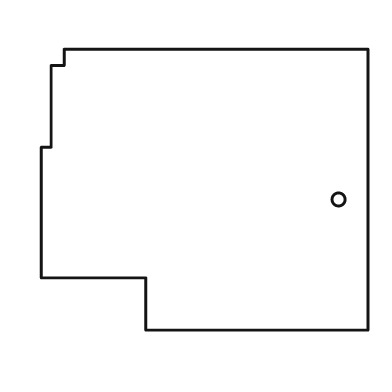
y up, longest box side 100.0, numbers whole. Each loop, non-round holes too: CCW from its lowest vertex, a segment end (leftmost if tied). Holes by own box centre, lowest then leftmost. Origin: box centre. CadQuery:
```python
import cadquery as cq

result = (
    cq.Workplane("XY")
    .moveTo(-18.0, -43.0)
    .lineTo(50.0, -43.0)
    .lineTo(50.0, 43.0)
    .lineTo(-43.0, 43.0)
    .lineTo(-43.0, 38.0)
    .lineTo(-47.0, 38.0)
    .lineTo(-47.0, 13.0)
    .lineTo(-50.0, 13.0)
    .lineTo(-50.0, -27.0)
    .lineTo(-18.0, -27.0)
    .close()
    .moveTo(41.0, -3.0)
    .circle(2.0)
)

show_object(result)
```